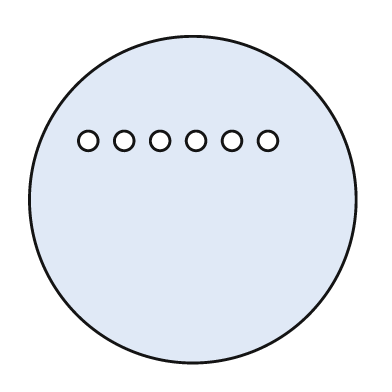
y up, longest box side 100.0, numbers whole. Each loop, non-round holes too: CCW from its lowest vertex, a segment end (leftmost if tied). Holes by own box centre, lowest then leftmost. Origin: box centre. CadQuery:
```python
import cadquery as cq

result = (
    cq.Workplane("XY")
    .moveTo(0.0, 0.0)
    .circle(50.0)
    .moveTo(-32.0, 18.0)
    .circle(3.0)
    .moveTo(-21.0, 18.0)
    .circle(3.0)
    .moveTo(-10.0, 18.0)
    .circle(3.0)
    .moveTo(1.0, 18.0)
    .circle(3.0)
    .moveTo(12.0, 18.0)
    .circle(3.0)
    .moveTo(23.0, 18.0)
    .circle(3.0)
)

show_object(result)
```